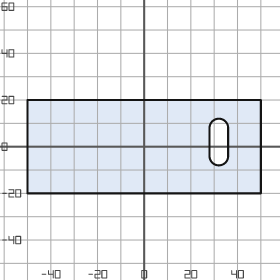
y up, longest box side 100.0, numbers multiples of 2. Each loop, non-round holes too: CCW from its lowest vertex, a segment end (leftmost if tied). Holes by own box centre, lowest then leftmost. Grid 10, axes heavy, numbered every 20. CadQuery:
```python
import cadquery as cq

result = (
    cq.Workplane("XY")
    .moveTo(-50.0, -20.0)
    .lineTo(50.0, -20.0)
    .lineTo(50.0, 20.0)
    .lineTo(-50.0, 20.0)
    .close()
    .moveTo(28.0, -4.0)
    .threePointArc((32.0, -8.0), (36.0, -4.0))
    .lineTo(36.0, 8.0)
    .threePointArc((32.0, 12.0), (28.0, 8.0))
    .close()
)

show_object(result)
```